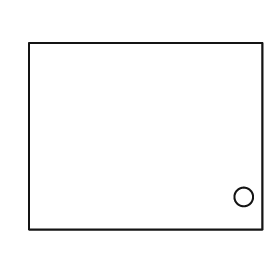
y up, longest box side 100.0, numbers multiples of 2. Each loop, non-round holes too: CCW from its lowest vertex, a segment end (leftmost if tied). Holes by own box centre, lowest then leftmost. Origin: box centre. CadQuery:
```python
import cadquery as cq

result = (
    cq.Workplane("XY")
    .moveTo(-50.0, -40.0)
    .lineTo(50.0, -40.0)
    .lineTo(50.0, 40.0)
    .lineTo(-50.0, 40.0)
    .close()
    .moveTo(42.0, -26.0)
    .circle(4.0)
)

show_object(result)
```